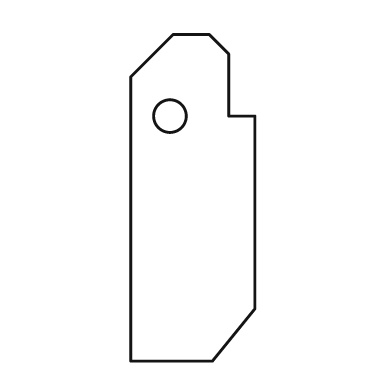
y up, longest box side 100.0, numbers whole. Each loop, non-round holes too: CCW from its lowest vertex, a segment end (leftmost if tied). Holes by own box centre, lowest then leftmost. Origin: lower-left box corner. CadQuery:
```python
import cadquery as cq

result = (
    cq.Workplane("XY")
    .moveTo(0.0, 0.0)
    .lineTo(25.0, 0.0)
    .lineTo(38.0, 16.0)
    .lineTo(38.0, 75.0)
    .lineTo(30.0, 75.0)
    .lineTo(30.0, 94.0)
    .lineTo(24.0, 100.0)
    .lineTo(13.0, 100.0)
    .lineTo(0.0, 87.0)
    .close()
    .moveTo(12.0, 75.0)
    .circle(5.0)
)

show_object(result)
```